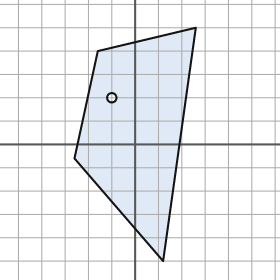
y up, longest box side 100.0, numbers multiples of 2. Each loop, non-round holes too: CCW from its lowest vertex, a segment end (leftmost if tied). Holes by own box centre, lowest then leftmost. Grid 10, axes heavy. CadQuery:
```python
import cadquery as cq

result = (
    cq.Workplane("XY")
    .moveTo(12.0, -50.0)
    .lineTo(26.0, 50.0)
    .lineTo(-16.0, 40.0)
    .lineTo(-26.0, -6.0)
    .close()
    .moveTo(-10.0, 20.0)
    .circle(2.0)
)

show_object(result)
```